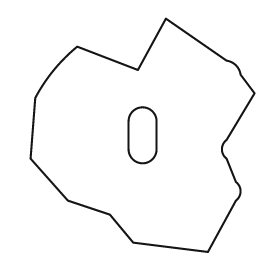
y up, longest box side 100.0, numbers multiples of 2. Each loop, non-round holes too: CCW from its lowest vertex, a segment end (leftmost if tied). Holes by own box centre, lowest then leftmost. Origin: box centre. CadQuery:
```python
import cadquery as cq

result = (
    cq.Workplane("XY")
    .moveTo(28.0, -50.0)
    .lineTo(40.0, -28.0)
    .threePointArc((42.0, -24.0), (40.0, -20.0))
    .lineTo(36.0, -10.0)
    .threePointArc((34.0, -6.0), (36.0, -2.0))
    .lineTo(48.0, 18.0)
    .lineTo(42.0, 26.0)
    .threePointArc((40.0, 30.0), (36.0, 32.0))
    .lineTo(10.0, 50.0)
    .lineTo(-2.0, 28.0)
    .lineTo(-28.0, 38.0)
    .threePointArc((-38.0, 28.0), (-46.0, 16.0))
    .lineTo(-48.0, -10.0)
    .lineTo(-32.0, -28.0)
    .lineTo(-14.0, -34.0)
    .lineTo(-4.0, -46.0)
    .close()
    .moveTo(-6.0, -6.0)
    .threePointArc((0.0, -12.0), (6.0, -6.0))
    .lineTo(6.0, 6.0)
    .threePointArc((0.0, 12.0), (-6.0, 6.0))
    .close()
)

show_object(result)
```